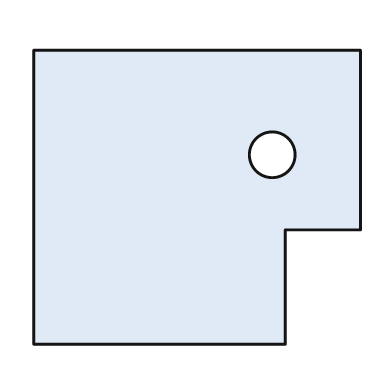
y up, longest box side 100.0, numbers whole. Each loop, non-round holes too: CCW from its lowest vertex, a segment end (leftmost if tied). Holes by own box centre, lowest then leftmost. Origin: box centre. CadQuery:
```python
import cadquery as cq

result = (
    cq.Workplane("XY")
    .moveTo(-50.0, -45.0)
    .lineTo(27.0, -45.0)
    .lineTo(27.0, -10.0)
    .lineTo(50.0, -10.0)
    .lineTo(50.0, 45.0)
    .lineTo(-50.0, 45.0)
    .close()
    .moveTo(23.0, 13.0)
    .circle(7.0)
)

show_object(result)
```